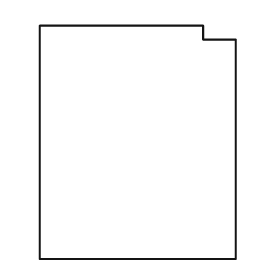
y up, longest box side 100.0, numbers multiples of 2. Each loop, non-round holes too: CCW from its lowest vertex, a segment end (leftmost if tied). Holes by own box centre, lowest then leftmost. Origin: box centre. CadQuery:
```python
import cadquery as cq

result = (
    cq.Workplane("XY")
    .moveTo(-42.0, -50.0)
    .lineTo(42.0, -50.0)
    .lineTo(42.0, 44.0)
    .lineTo(28.0, 44.0)
    .lineTo(28.0, 50.0)
    .lineTo(-42.0, 50.0)
    .close()
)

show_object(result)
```